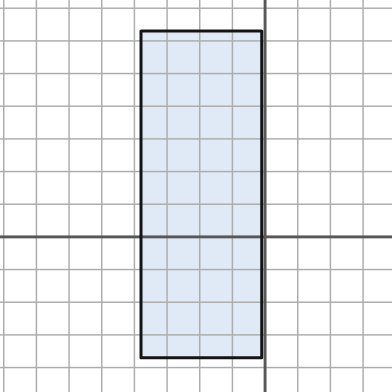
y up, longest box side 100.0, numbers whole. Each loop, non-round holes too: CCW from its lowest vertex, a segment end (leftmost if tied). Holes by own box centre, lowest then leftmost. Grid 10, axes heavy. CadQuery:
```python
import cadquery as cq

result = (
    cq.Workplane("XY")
    .moveTo(-38.0, -37.0)
    .lineTo(-1.0, -37.0)
    .lineTo(-1.0, 63.0)
    .lineTo(-38.0, 63.0)
    .close()
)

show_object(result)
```